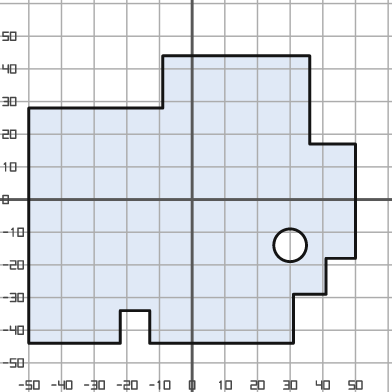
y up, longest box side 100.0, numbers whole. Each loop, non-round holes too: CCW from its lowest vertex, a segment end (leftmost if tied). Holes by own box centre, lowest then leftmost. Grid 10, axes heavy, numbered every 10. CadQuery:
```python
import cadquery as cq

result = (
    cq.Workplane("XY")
    .moveTo(-50.0, -44.0)
    .lineTo(-22.0, -44.0)
    .lineTo(-22.0, -34.0)
    .lineTo(-13.0, -34.0)
    .lineTo(-13.0, -44.0)
    .lineTo(31.0, -44.0)
    .lineTo(31.0, -29.0)
    .lineTo(41.0, -29.0)
    .lineTo(41.0, -18.0)
    .lineTo(50.0, -18.0)
    .lineTo(50.0, 17.0)
    .lineTo(36.0, 17.0)
    .lineTo(36.0, 44.0)
    .lineTo(-9.0, 44.0)
    .lineTo(-9.0, 28.0)
    .lineTo(-50.0, 28.0)
    .close()
    .moveTo(30.0, -14.0)
    .circle(5.0)
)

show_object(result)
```